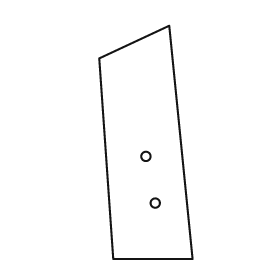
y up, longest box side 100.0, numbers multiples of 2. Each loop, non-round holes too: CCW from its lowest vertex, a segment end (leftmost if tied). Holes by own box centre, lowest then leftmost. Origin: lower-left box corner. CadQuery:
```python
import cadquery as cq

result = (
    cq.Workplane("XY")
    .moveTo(6.0, 0.0)
    .lineTo(40.0, 0.0)
    .lineTo(30.0, 100.0)
    .lineTo(0.0, 86.0)
    .close()
    .moveTo(24.0, 24.0)
    .circle(2.0)
    .moveTo(20.0, 44.0)
    .circle(2.0)
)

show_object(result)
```